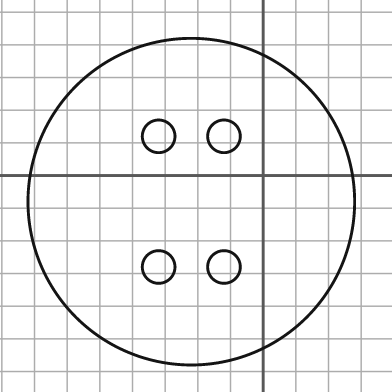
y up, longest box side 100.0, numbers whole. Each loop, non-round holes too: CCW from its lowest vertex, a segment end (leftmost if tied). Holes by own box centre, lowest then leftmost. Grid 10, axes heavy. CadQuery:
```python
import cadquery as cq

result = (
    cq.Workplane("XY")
    .moveTo(-22.0, -8.0)
    .circle(50.0)
    .moveTo(-32.0, -28.0)
    .circle(5.0)
    .moveTo(-12.0, -28.0)
    .circle(5.0)
    .moveTo(-32.0, 12.0)
    .circle(5.0)
    .moveTo(-12.0, 12.0)
    .circle(5.0)
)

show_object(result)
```